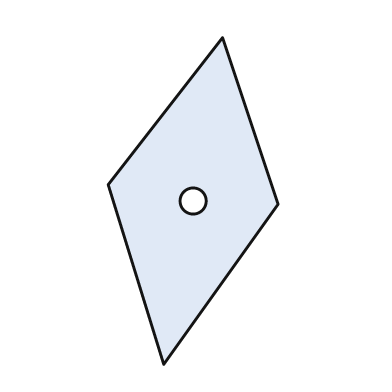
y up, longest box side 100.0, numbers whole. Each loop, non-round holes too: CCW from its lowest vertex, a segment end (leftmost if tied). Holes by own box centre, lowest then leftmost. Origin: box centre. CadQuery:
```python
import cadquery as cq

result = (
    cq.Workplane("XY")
    .moveTo(-9.0, -50.0)
    .lineTo(26.0, -1.0)
    .lineTo(9.0, 50.0)
    .lineTo(-26.0, 5.0)
    .close()
    .moveTo(0.0, 0.0)
    .circle(4.0)
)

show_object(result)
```